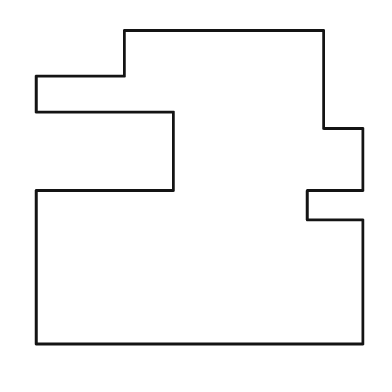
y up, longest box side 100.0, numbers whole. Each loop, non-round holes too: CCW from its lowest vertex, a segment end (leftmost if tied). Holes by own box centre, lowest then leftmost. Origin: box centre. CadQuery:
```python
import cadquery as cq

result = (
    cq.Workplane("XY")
    .moveTo(-50.0, -48.0)
    .lineTo(50.0, -48.0)
    .lineTo(50.0, -10.0)
    .lineTo(33.0, -10.0)
    .lineTo(33.0, -1.0)
    .lineTo(50.0, -1.0)
    .lineTo(50.0, 18.0)
    .lineTo(38.0, 18.0)
    .lineTo(38.0, 48.0)
    .lineTo(-23.0, 48.0)
    .lineTo(-23.0, 34.0)
    .lineTo(-50.0, 34.0)
    .lineTo(-50.0, 23.0)
    .lineTo(-8.0, 23.0)
    .lineTo(-8.0, -1.0)
    .lineTo(-50.0, -1.0)
    .close()
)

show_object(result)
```